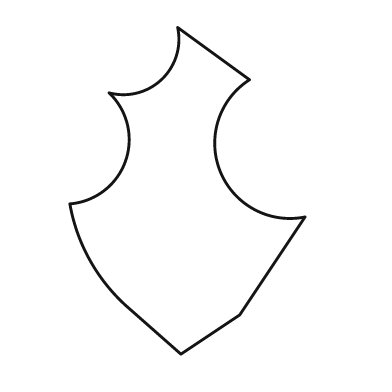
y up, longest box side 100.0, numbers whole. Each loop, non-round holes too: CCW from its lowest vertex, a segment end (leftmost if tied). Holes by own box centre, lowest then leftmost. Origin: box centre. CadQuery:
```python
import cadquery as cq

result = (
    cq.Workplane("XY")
    .moveTo(-2.0, -50.0)
    .lineTo(16.0, -38.0)
    .lineTo(36.0, -8.0)
    .threePointArc((10.0, 6.0), (19.0, 34.0))
    .lineTo(-3.0, 50.0)
    .threePointArc((-8.0, 34.0), (-24.0, 30.0))
    .threePointArc((-19.0, 9.0), (-36.0, -4.0))
    .threePointArc((-30.0, -21.0), (-19.0, -35.0))
    .close()
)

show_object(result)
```